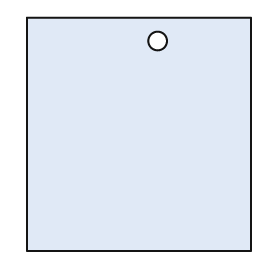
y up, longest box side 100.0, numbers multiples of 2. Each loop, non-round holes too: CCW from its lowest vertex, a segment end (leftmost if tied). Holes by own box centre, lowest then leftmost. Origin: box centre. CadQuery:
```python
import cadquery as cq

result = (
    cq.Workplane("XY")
    .moveTo(-48.0, -50.0)
    .lineTo(48.0, -50.0)
    .lineTo(48.0, 50.0)
    .lineTo(-48.0, 50.0)
    .close()
    .moveTo(8.0, 40.0)
    .circle(4.0)
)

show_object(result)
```